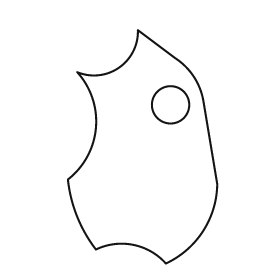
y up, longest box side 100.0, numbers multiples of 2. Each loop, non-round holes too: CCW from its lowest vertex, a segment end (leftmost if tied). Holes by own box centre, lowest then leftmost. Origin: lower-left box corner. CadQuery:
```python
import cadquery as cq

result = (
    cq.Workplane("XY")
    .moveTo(42.0, 0.0)
    .threePointArc((58.0, 14.0), (64.0, 34.0))
    .lineTo(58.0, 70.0)
    .threePointArc((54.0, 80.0), (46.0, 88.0))
    .lineTo(30.0, 100.0)
    .threePointArc((22.0, 84.0), (4.0, 82.0))
    .threePointArc((12.0, 58.0), (0.0, 36.0))
    .threePointArc((4.0, 20.0), (12.0, 6.0))
    .threePointArc((28.0, 8.0), (42.0, 0.0))
    .close()
    .moveTo(44.0, 68.0)
    .circle(8.0)
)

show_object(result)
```